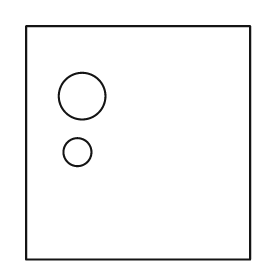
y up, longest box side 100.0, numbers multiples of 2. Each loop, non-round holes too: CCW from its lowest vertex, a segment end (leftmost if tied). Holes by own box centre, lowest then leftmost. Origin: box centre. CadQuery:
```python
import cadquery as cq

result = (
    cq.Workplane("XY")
    .moveTo(-48.0, -50.0)
    .lineTo(48.0, -50.0)
    .lineTo(48.0, 50.0)
    .lineTo(-48.0, 50.0)
    .close()
    .moveTo(-26.0, -4.0)
    .circle(6.0)
    .moveTo(-24.0, 20.0)
    .circle(10.0)
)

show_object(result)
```